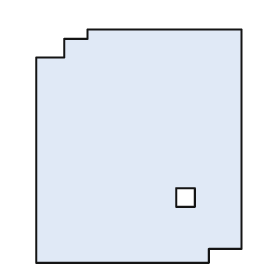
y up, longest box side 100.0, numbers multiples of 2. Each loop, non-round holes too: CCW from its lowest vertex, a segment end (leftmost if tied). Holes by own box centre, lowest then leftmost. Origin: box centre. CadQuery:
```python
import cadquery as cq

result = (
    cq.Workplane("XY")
    .moveTo(-44.0, -50.0)
    .lineTo(30.0, -50.0)
    .lineTo(30.0, -44.0)
    .lineTo(44.0, -44.0)
    .lineTo(44.0, 50.0)
    .lineTo(-22.0, 50.0)
    .lineTo(-22.0, 46.0)
    .lineTo(-32.0, 46.0)
    .lineTo(-32.0, 38.0)
    .lineTo(-44.0, 38.0)
    .close()
    .moveTo(16.0, -26.0)
    .lineTo(24.0, -26.0)
    .lineTo(24.0, -18.0)
    .lineTo(16.0, -18.0)
    .close()
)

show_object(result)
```